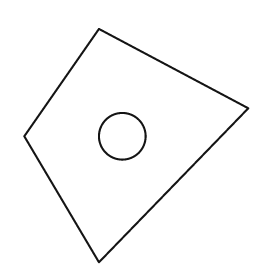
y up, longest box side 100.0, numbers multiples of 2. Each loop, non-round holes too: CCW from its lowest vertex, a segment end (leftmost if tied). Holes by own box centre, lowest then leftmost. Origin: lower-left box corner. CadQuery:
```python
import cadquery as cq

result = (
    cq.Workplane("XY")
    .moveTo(32.0, 0.0)
    .lineTo(96.0, 66.0)
    .lineTo(32.0, 100.0)
    .lineTo(0.0, 54.0)
    .close()
    .moveTo(42.0, 54.0)
    .circle(10.0)
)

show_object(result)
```